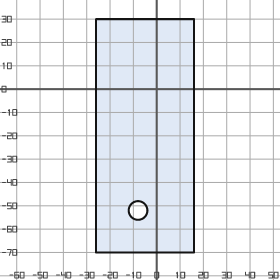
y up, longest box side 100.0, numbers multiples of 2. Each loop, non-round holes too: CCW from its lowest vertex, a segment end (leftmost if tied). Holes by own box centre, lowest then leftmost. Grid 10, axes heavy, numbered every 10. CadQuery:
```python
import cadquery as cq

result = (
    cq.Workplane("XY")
    .moveTo(-26.0, -70.0)
    .lineTo(16.0, -70.0)
    .lineTo(16.0, 30.0)
    .lineTo(-26.0, 30.0)
    .close()
    .moveTo(-8.0, -52.0)
    .circle(4.0)
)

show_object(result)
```